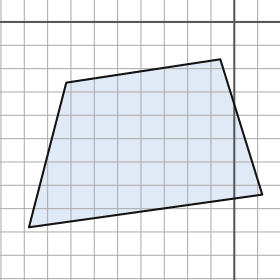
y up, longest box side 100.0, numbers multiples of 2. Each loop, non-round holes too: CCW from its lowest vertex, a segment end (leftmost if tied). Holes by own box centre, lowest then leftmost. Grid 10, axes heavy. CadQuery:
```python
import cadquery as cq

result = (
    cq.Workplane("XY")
    .moveTo(-88.0, -88.0)
    .lineTo(12.0, -74.0)
    .lineTo(-6.0, -16.0)
    .lineTo(-72.0, -26.0)
    .close()
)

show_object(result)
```